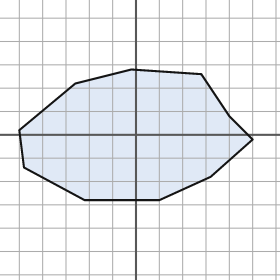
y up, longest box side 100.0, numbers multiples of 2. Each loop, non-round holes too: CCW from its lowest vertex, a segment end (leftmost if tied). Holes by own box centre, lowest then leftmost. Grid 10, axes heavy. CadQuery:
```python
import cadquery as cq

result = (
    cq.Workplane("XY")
    .moveTo(-22.0, -28.0)
    .lineTo(10.0, -28.0)
    .lineTo(32.0, -18.0)
    .lineTo(50.0, -2.0)
    .lineTo(40.0, 8.0)
    .lineTo(28.0, 26.0)
    .lineTo(-2.0, 28.0)
    .lineTo(-26.0, 22.0)
    .lineTo(-50.0, 2.0)
    .lineTo(-48.0, -14.0)
    .close()
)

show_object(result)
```